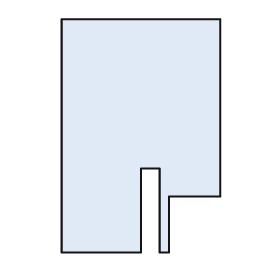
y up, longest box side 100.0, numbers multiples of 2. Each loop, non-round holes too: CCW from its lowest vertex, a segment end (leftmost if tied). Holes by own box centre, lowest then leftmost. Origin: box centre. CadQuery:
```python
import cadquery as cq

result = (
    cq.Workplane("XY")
    .moveTo(-34.0, -50.0)
    .lineTo(0.0, -50.0)
    .lineTo(0.0, -14.0)
    .lineTo(8.0, -14.0)
    .lineTo(8.0, -50.0)
    .lineTo(12.0, -50.0)
    .lineTo(12.0, -26.0)
    .lineTo(34.0, -26.0)
    .lineTo(34.0, 50.0)
    .lineTo(-34.0, 50.0)
    .close()
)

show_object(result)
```